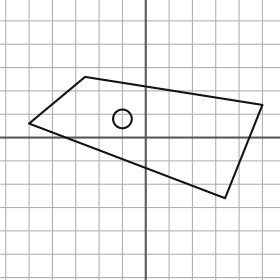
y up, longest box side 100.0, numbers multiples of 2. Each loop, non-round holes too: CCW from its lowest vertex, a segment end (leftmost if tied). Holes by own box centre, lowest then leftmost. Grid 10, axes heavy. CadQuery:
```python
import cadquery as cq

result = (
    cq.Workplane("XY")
    .moveTo(34.0, -26.0)
    .lineTo(50.0, 14.0)
    .lineTo(-26.0, 26.0)
    .lineTo(-50.0, 6.0)
    .close()
    .moveTo(-10.0, 8.0)
    .circle(4.0)
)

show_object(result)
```